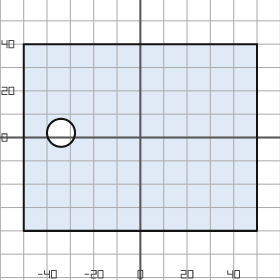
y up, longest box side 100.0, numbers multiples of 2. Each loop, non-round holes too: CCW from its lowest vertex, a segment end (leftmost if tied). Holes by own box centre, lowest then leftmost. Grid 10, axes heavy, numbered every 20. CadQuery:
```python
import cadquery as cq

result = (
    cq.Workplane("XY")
    .moveTo(-50.0, -40.0)
    .lineTo(50.0, -40.0)
    .lineTo(50.0, 40.0)
    .lineTo(-50.0, 40.0)
    .close()
    .moveTo(-34.0, 2.0)
    .circle(6.0)
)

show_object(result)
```